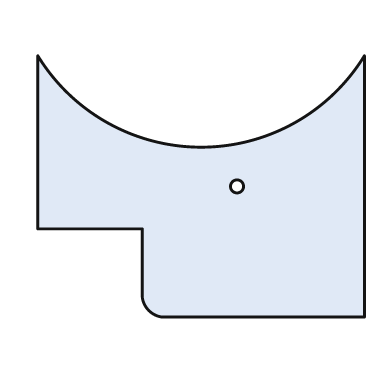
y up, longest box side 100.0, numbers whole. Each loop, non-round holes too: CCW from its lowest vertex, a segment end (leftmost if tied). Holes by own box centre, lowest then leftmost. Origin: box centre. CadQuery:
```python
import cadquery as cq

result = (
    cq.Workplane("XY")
    .moveTo(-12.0, -40.0)
    .lineTo(50.0, -40.0)
    .lineTo(50.0, 40.0)
    .threePointArc((0.0, 12.0), (-50.0, 40.0))
    .lineTo(-50.0, -13.0)
    .lineTo(-18.0, -13.0)
    .lineTo(-18.0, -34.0)
    .threePointArc((-16.0, -38.0), (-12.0, -40.0))
    .close()
    .moveTo(11.0, 0.0)
    .circle(2.0)
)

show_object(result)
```